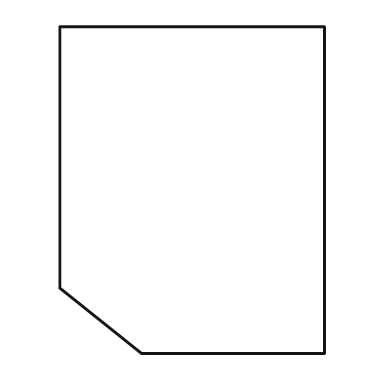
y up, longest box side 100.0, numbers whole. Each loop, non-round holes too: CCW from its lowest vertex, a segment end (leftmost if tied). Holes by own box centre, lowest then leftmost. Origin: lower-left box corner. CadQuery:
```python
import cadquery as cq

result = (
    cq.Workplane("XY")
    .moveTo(25.0, 0.0)
    .lineTo(81.0, 0.0)
    .lineTo(81.0, 100.0)
    .lineTo(0.0, 100.0)
    .lineTo(0.0, 20.0)
    .close()
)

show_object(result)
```